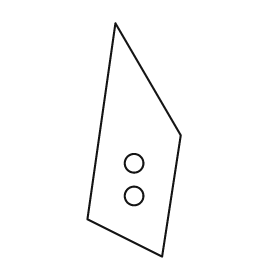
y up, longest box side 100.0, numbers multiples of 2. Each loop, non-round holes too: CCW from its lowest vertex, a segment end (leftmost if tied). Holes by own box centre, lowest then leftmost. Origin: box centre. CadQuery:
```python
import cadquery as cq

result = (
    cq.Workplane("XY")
    .moveTo(12.0, -50.0)
    .lineTo(20.0, 2.0)
    .lineTo(-8.0, 50.0)
    .lineTo(-20.0, -34.0)
    .close()
    .moveTo(0.0, -24.0)
    .circle(4.0)
    .moveTo(0.0, -10.0)
    .circle(4.0)
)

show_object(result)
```